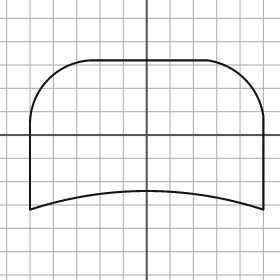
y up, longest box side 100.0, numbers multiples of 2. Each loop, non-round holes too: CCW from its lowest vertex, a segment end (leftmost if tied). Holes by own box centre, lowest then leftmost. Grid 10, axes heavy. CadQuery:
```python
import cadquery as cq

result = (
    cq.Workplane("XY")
    .moveTo(-50.0, -32.0)
    .threePointArc((0.0, -24.0), (50.0, -32.0))
    .lineTo(50.0, 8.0)
    .threePointArc((42.0, 24.0), (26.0, 32.0))
    .lineTo(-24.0, 32.0)
    .threePointArc((-42.0, 24.0), (-50.0, 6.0))
    .close()
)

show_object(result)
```